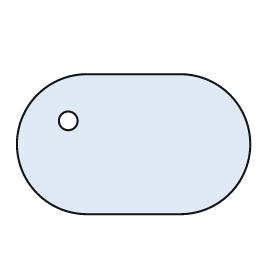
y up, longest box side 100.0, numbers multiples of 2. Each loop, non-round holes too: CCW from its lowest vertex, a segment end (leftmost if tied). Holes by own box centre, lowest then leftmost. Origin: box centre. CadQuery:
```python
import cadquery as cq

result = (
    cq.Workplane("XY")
    .moveTo(-20.0, -30.0)
    .lineTo(20.0, -30.0)
    .threePointArc((50.0, 0.0), (20.0, 30.0))
    .lineTo(-20.0, 30.0)
    .threePointArc((-50.0, 0.0), (-20.0, -30.0))
    .close()
    .moveTo(-28.0, 10.0)
    .circle(4.0)
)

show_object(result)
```